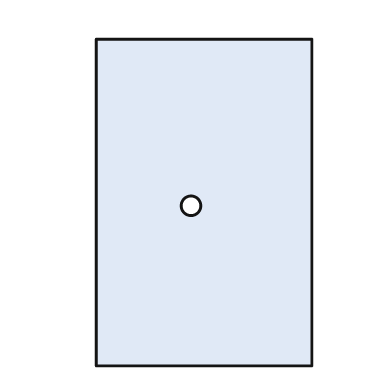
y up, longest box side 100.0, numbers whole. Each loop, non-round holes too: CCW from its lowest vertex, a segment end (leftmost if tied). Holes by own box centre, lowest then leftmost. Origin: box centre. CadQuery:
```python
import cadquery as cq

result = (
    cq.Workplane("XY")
    .moveTo(-33.0, -50.0)
    .lineTo(33.0, -50.0)
    .lineTo(33.0, 50.0)
    .lineTo(-33.0, 50.0)
    .close()
    .moveTo(-4.0, -1.0)
    .circle(3.0)
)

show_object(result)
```